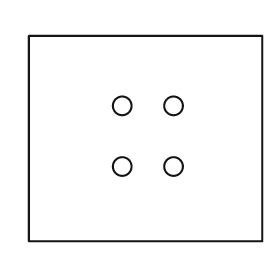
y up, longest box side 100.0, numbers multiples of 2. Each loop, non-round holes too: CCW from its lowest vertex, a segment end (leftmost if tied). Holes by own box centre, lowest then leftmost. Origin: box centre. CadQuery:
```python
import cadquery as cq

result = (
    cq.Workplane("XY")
    .moveTo(-50.0, -44.0)
    .lineTo(50.0, -44.0)
    .lineTo(50.0, 44.0)
    .lineTo(-50.0, 44.0)
    .close()
    .moveTo(-10.0, -12.0)
    .circle(4.0)
    .moveTo(12.0, -12.0)
    .circle(4.0)
    .moveTo(-10.0, 14.0)
    .circle(4.0)
    .moveTo(12.0, 14.0)
    .circle(4.0)
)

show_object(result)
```